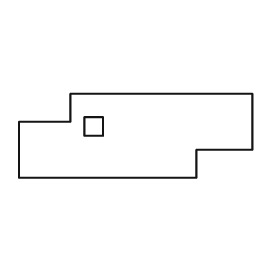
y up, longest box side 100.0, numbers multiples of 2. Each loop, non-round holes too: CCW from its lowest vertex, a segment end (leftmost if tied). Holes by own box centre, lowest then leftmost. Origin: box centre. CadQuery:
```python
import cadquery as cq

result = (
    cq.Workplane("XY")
    .moveTo(-50.0, -18.0)
    .lineTo(26.0, -18.0)
    .lineTo(26.0, -6.0)
    .lineTo(50.0, -6.0)
    .lineTo(50.0, 18.0)
    .lineTo(-28.0, 18.0)
    .lineTo(-28.0, 6.0)
    .lineTo(-50.0, 6.0)
    .close()
    .moveTo(-22.0, 0.0)
    .lineTo(-14.0, 0.0)
    .lineTo(-14.0, 8.0)
    .lineTo(-22.0, 8.0)
    .close()
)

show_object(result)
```